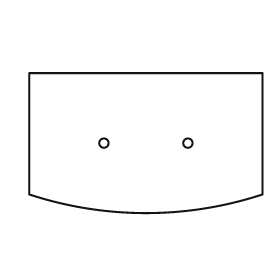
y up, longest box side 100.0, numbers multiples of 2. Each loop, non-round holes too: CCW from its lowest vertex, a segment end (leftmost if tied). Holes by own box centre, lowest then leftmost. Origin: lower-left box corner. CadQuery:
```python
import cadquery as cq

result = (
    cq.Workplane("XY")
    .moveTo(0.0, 8.0)
    .threePointArc((50.0, 0.0), (100.0, 8.0))
    .lineTo(100.0, 60.0)
    .lineTo(0.0, 60.0)
    .close()
    .moveTo(32.0, 30.0)
    .circle(2.0)
    .moveTo(68.0, 30.0)
    .circle(2.0)
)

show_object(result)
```